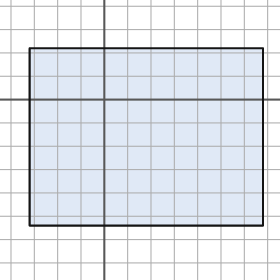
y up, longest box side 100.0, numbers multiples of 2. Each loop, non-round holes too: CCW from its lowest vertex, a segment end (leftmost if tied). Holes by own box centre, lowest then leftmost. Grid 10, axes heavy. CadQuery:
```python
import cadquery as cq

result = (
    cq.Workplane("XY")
    .moveTo(-32.0, -54.0)
    .lineTo(68.0, -54.0)
    .lineTo(68.0, 22.0)
    .lineTo(-32.0, 22.0)
    .close()
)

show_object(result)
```